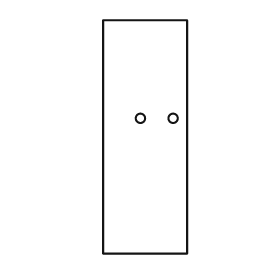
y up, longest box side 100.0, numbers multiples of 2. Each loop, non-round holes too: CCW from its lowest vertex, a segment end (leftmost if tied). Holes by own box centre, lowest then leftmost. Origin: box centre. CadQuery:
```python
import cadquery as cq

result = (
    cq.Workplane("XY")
    .moveTo(-18.0, -50.0)
    .lineTo(18.0, -50.0)
    .lineTo(18.0, 50.0)
    .lineTo(-18.0, 50.0)
    .close()
    .moveTo(-2.0, 8.0)
    .circle(2.0)
    .moveTo(12.0, 8.0)
    .circle(2.0)
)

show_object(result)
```